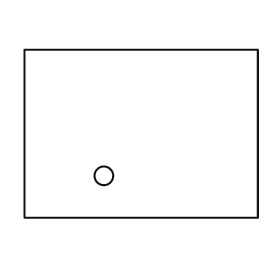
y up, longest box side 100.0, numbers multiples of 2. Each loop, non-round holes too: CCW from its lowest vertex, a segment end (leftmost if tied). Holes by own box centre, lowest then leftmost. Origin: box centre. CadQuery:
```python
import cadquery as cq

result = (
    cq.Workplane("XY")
    .moveTo(-50.0, -36.0)
    .lineTo(50.0, -36.0)
    .lineTo(50.0, 36.0)
    .lineTo(-50.0, 36.0)
    .close()
    .moveTo(-16.0, -18.0)
    .circle(4.0)
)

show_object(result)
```